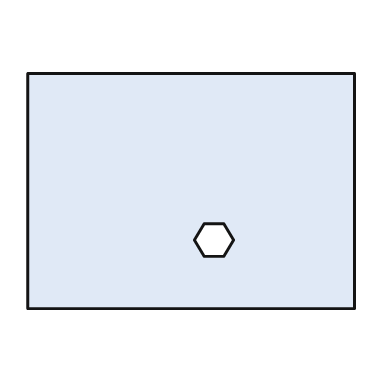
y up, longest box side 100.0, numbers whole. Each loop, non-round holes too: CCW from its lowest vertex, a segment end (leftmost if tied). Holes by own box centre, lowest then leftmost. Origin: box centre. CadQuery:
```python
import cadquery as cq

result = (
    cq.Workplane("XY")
    .moveTo(-50.0, -36.0)
    .lineTo(50.0, -36.0)
    .lineTo(50.0, 36.0)
    .lineTo(-50.0, 36.0)
    .close()
    .moveTo(4.0, -20.0)
    .lineTo(10.0, -20.0)
    .lineTo(13.0, -15.0)
    .lineTo(10.0, -10.0)
    .lineTo(4.0, -10.0)
    .lineTo(1.0, -15.0)
    .close()
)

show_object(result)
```